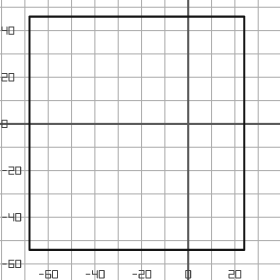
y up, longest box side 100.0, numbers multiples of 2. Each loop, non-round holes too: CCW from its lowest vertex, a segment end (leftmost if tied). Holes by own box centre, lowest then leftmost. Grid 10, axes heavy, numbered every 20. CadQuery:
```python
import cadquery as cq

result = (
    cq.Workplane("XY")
    .moveTo(-68.0, -54.0)
    .lineTo(24.0, -54.0)
    .lineTo(24.0, 46.0)
    .lineTo(-68.0, 46.0)
    .close()
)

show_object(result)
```